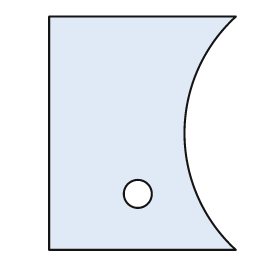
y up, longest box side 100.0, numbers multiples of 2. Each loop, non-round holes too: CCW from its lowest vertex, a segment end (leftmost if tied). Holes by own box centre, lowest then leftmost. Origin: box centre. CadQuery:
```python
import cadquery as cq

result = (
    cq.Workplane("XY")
    .moveTo(-40.0, -50.0)
    .lineTo(40.0, -50.0)
    .threePointArc((18.0, 0.0), (40.0, 50.0))
    .lineTo(-40.0, 50.0)
    .close()
    .moveTo(-2.0, -26.0)
    .circle(6.0)
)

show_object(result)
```